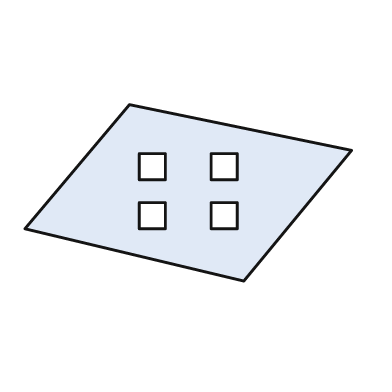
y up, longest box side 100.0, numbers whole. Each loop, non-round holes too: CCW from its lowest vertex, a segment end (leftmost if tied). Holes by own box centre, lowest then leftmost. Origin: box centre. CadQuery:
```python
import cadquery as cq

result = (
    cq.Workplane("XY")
    .moveTo(17.0, -27.0)
    .lineTo(50.0, 13.0)
    .lineTo(-18.0, 27.0)
    .lineTo(-50.0, -11.0)
    .close()
    .moveTo(-15.0, -11.0)
    .lineTo(-7.0, -11.0)
    .lineTo(-7.0, -3.0)
    .lineTo(-15.0, -3.0)
    .close()
    .moveTo(7.0, -11.0)
    .lineTo(15.0, -11.0)
    .lineTo(15.0, -3.0)
    .lineTo(7.0, -3.0)
    .close()
    .moveTo(-15.0, 4.0)
    .lineTo(-7.0, 4.0)
    .lineTo(-7.0, 12.0)
    .lineTo(-15.0, 12.0)
    .close()
    .moveTo(7.0, 4.0)
    .lineTo(15.0, 4.0)
    .lineTo(15.0, 12.0)
    .lineTo(7.0, 12.0)
    .close()
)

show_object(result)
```